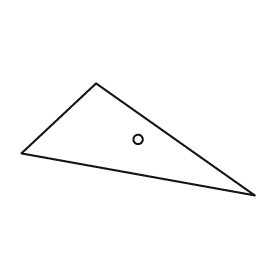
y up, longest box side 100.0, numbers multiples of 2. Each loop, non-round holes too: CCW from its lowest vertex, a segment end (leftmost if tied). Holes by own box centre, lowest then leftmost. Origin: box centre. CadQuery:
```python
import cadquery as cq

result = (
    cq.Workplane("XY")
    .moveTo(50.0, -24.0)
    .lineTo(-18.0, 24.0)
    .lineTo(-50.0, -6.0)
    .close()
    .moveTo(0.0, 0.0)
    .circle(2.0)
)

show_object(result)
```